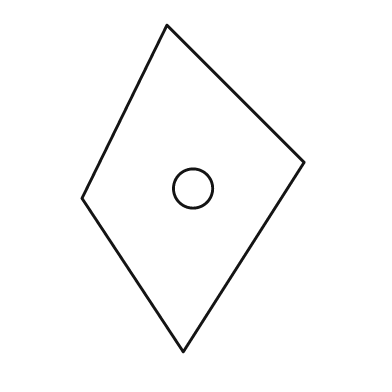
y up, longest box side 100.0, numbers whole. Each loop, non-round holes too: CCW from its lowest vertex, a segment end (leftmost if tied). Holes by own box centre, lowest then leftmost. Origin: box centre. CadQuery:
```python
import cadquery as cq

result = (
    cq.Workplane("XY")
    .moveTo(-3.0, -50.0)
    .lineTo(34.0, 8.0)
    .lineTo(-8.0, 50.0)
    .lineTo(-34.0, -3.0)
    .close()
    .moveTo(0.0, 0.0)
    .circle(6.0)
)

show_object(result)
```